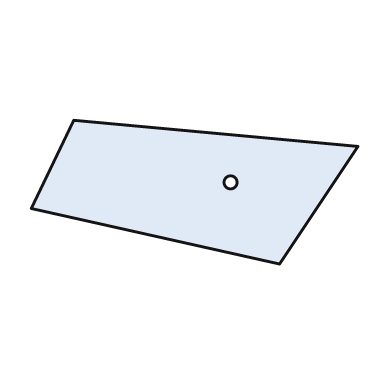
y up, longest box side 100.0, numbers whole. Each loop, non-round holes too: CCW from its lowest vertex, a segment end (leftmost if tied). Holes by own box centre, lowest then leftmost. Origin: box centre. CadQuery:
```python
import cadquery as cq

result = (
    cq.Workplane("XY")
    .moveTo(26.0, -22.0)
    .lineTo(50.0, 14.0)
    .lineTo(-37.0, 22.0)
    .lineTo(-50.0, -5.0)
    .close()
    .moveTo(11.0, 3.0)
    .circle(2.0)
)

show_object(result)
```